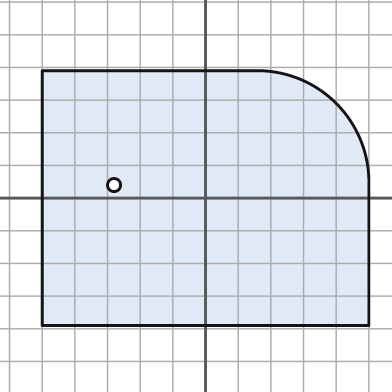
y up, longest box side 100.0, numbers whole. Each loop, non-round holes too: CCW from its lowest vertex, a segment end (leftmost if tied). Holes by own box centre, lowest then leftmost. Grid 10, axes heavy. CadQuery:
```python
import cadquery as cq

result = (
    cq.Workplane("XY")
    .moveTo(-50.0, -39.0)
    .lineTo(50.0, -39.0)
    .lineTo(50.0, 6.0)
    .threePointArc((40.0, 29.0), (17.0, 39.0))
    .lineTo(-50.0, 39.0)
    .close()
    .moveTo(-28.0, 4.0)
    .circle(2.0)
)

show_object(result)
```